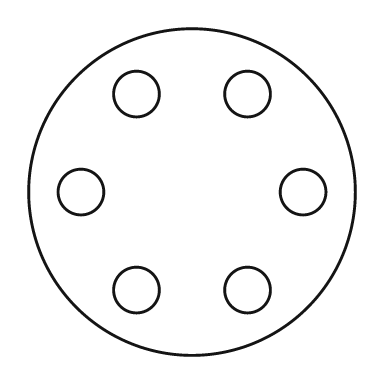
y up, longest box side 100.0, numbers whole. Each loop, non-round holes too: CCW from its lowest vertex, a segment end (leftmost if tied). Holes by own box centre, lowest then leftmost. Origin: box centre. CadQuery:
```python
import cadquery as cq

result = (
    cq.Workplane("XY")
    .moveTo(0.0, 0.0)
    .circle(50.0)
    .moveTo(-17.0, -30.0)
    .circle(7.0)
    .moveTo(17.0, -30.0)
    .circle(7.0)
    .moveTo(-34.0, 0.0)
    .circle(7.0)
    .moveTo(34.0, 0.0)
    .circle(7.0)
    .moveTo(-17.0, 30.0)
    .circle(7.0)
    .moveTo(17.0, 30.0)
    .circle(7.0)
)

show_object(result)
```